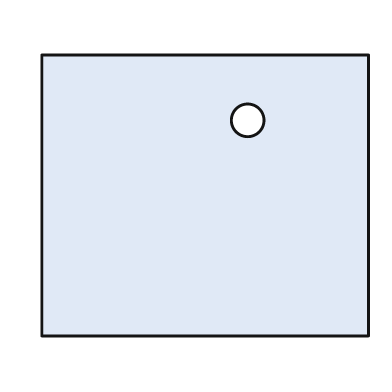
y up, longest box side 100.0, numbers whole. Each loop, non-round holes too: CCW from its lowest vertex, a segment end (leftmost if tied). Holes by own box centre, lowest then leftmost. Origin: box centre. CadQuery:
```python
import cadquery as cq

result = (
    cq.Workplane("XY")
    .moveTo(-50.0, -43.0)
    .lineTo(50.0, -43.0)
    .lineTo(50.0, 43.0)
    .lineTo(-50.0, 43.0)
    .close()
    .moveTo(13.0, 23.0)
    .circle(5.0)
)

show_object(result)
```